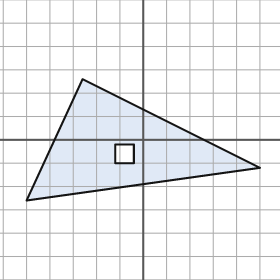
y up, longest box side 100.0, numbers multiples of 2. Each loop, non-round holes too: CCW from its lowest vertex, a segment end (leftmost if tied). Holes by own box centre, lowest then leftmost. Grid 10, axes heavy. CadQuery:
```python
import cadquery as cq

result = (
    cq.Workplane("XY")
    .moveTo(-50.0, -26.0)
    .lineTo(50.0, -12.0)
    .lineTo(-26.0, 26.0)
    .close()
    .moveTo(-12.0, -10.0)
    .lineTo(-4.0, -10.0)
    .lineTo(-4.0, -2.0)
    .lineTo(-12.0, -2.0)
    .close()
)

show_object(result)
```